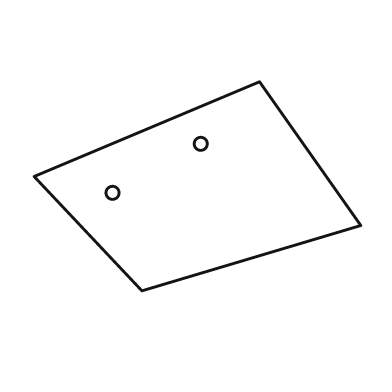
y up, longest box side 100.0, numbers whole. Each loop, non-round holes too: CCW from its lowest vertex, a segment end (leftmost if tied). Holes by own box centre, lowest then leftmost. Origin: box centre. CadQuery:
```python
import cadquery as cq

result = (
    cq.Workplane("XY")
    .moveTo(-17.0, -32.0)
    .lineTo(50.0, -12.0)
    .lineTo(19.0, 32.0)
    .lineTo(-50.0, 3.0)
    .close()
    .moveTo(-26.0, -2.0)
    .circle(2.0)
    .moveTo(1.0, 13.0)
    .circle(2.0)
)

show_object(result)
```